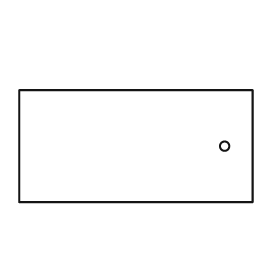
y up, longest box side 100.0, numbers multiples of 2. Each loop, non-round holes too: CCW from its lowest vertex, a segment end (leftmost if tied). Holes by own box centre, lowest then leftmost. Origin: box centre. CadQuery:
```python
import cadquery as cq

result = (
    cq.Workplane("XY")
    .moveTo(-50.0, -24.0)
    .lineTo(50.0, -24.0)
    .lineTo(50.0, 24.0)
    .lineTo(-50.0, 24.0)
    .close()
    .moveTo(38.0, 0.0)
    .circle(2.0)
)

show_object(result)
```